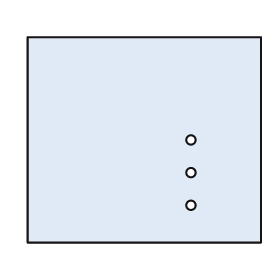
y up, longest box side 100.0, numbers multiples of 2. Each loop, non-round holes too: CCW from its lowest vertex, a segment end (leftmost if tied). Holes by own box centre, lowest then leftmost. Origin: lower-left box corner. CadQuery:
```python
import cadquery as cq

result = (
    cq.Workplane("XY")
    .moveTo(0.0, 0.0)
    .lineTo(100.0, 0.0)
    .lineTo(100.0, 88.0)
    .lineTo(0.0, 88.0)
    .close()
    .moveTo(70.0, 16.0)
    .circle(2.0)
    .moveTo(70.0, 30.0)
    .circle(2.0)
    .moveTo(70.0, 44.0)
    .circle(2.0)
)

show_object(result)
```